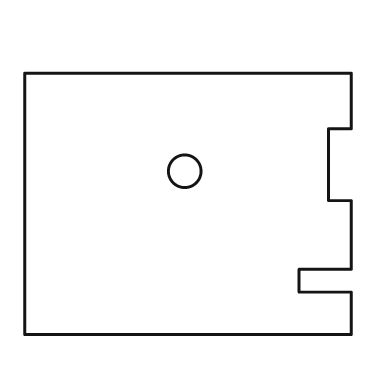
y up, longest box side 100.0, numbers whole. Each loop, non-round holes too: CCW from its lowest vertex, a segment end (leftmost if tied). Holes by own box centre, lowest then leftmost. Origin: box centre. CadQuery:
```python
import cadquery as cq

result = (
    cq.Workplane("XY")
    .moveTo(-50.0, -40.0)
    .lineTo(50.0, -40.0)
    .lineTo(50.0, -27.0)
    .lineTo(34.0, -27.0)
    .lineTo(34.0, -20.0)
    .lineTo(50.0, -20.0)
    .lineTo(50.0, 1.0)
    .lineTo(43.0, 1.0)
    .lineTo(43.0, 23.0)
    .lineTo(50.0, 23.0)
    .lineTo(50.0, 40.0)
    .lineTo(-50.0, 40.0)
    .close()
    .moveTo(-1.0, 10.0)
    .circle(5.0)
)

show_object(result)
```